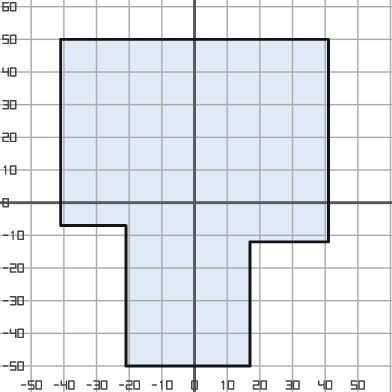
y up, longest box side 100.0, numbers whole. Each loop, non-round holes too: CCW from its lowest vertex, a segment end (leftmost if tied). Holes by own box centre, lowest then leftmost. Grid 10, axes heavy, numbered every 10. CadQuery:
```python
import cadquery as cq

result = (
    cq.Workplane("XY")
    .moveTo(-21.0, -50.0)
    .lineTo(17.0, -50.0)
    .lineTo(17.0, -12.0)
    .lineTo(41.0, -12.0)
    .lineTo(41.0, 50.0)
    .lineTo(-41.0, 50.0)
    .lineTo(-41.0, -7.0)
    .lineTo(-21.0, -7.0)
    .close()
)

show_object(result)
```